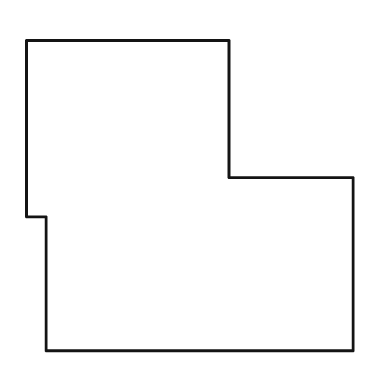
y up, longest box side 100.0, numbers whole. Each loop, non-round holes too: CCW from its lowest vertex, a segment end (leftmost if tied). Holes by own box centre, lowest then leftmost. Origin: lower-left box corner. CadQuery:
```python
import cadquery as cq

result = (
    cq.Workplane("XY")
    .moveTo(6.0, 0.0)
    .lineTo(100.0, 0.0)
    .lineTo(100.0, 53.0)
    .lineTo(62.0, 53.0)
    .lineTo(62.0, 95.0)
    .lineTo(0.0, 95.0)
    .lineTo(0.0, 41.0)
    .lineTo(6.0, 41.0)
    .close()
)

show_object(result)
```